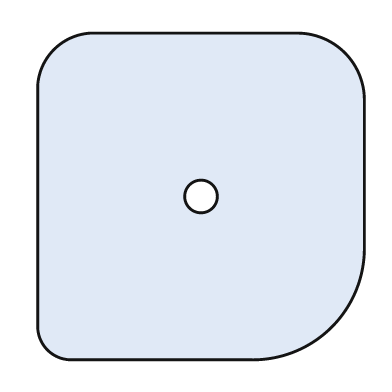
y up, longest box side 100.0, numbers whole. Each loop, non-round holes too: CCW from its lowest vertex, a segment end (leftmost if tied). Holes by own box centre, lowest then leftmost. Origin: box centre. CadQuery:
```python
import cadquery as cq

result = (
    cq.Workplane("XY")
    .moveTo(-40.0, -50.0)
    .lineTo(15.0, -50.0)
    .threePointArc((40.0, -40.0), (50.0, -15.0))
    .lineTo(50.0, 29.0)
    .threePointArc((44.0, 44.0), (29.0, 50.0))
    .lineTo(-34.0, 50.0)
    .threePointArc((-45.0, 45.0), (-50.0, 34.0))
    .lineTo(-50.0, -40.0)
    .threePointArc((-47.0, -47.0), (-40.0, -50.0))
    .close()
    .moveTo(0.0, 0.0)
    .circle(5.0)
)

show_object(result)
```